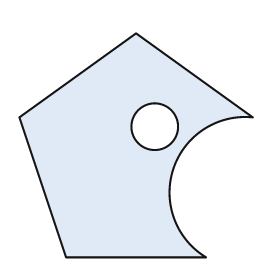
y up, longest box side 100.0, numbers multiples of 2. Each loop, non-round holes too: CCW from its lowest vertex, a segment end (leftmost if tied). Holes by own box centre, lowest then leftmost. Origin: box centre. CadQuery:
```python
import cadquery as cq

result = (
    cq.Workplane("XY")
    .moveTo(-30.0, -48.0)
    .lineTo(30.0, -48.0)
    .threePointArc((16.0, -10.0), (50.0, 12.0))
    .lineTo(0.0, 48.0)
    .lineTo(-50.0, 12.0)
    .close()
    .moveTo(8.0, 8.0)
    .circle(10.0)
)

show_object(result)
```